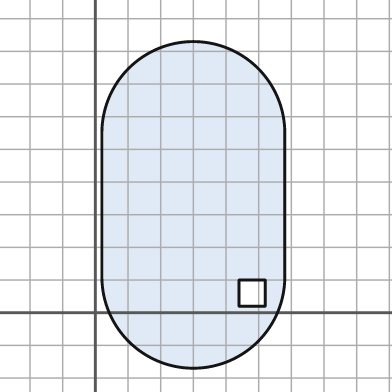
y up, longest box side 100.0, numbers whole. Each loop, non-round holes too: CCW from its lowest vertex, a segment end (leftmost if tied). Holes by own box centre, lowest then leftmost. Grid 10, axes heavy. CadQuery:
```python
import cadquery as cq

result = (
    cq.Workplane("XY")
    .moveTo(2.0, 11.0)
    .threePointArc((30.0, -17.0), (58.0, 11.0))
    .lineTo(58.0, 55.0)
    .threePointArc((30.0, 83.0), (2.0, 55.0))
    .close()
    .moveTo(44.0, 2.0)
    .lineTo(52.0, 2.0)
    .lineTo(52.0, 10.0)
    .lineTo(44.0, 10.0)
    .close()
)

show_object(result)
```